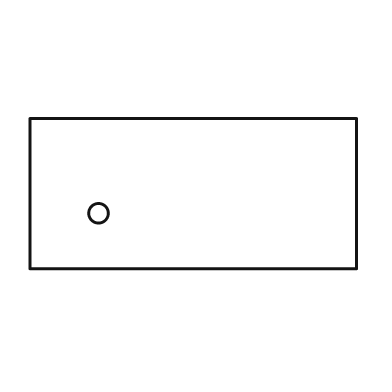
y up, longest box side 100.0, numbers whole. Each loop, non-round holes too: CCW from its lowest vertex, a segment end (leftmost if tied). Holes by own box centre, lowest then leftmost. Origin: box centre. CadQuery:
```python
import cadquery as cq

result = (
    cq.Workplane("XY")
    .moveTo(-50.0, -23.0)
    .lineTo(50.0, -23.0)
    .lineTo(50.0, 23.0)
    .lineTo(-50.0, 23.0)
    .close()
    .moveTo(-29.0, -6.0)
    .circle(3.0)
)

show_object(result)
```